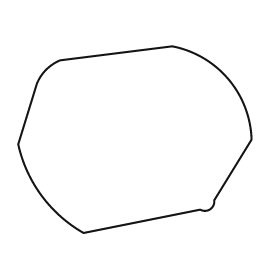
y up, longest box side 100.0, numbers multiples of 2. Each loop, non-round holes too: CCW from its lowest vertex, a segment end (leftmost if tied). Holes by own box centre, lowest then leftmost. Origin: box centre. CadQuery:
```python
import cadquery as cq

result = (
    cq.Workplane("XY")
    .moveTo(-22.0, -40.0)
    .lineTo(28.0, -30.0)
    .threePointArc((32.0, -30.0), (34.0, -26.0))
    .lineTo(50.0, 0.0)
    .threePointArc((40.0, 26.0), (16.0, 40.0))
    .lineTo(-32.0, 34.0)
    .threePointArc((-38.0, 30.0), (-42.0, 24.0))
    .lineTo(-50.0, -2.0)
    .threePointArc((-40.0, -24.0), (-22.0, -40.0))
    .close()
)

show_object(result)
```